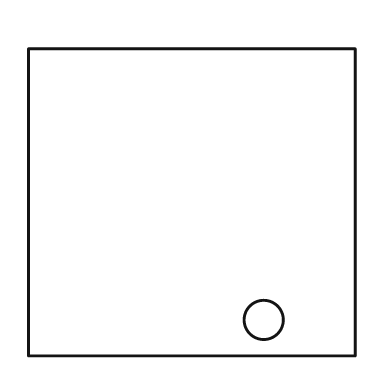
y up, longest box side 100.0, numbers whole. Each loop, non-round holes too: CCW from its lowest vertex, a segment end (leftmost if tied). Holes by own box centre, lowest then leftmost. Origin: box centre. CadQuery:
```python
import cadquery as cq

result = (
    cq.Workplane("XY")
    .moveTo(-50.0, -47.0)
    .lineTo(50.0, -47.0)
    .lineTo(50.0, 47.0)
    .lineTo(-50.0, 47.0)
    .close()
    .moveTo(22.0, -36.0)
    .circle(6.0)
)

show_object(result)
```